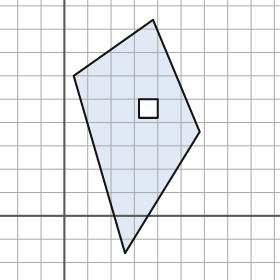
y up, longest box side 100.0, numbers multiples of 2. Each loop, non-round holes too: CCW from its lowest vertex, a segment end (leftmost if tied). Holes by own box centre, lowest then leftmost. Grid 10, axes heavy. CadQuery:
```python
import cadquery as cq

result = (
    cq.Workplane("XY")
    .moveTo(26.0, -16.0)
    .lineTo(58.0, 36.0)
    .lineTo(38.0, 84.0)
    .lineTo(4.0, 60.0)
    .close()
    .moveTo(32.0, 42.0)
    .lineTo(40.0, 42.0)
    .lineTo(40.0, 50.0)
    .lineTo(32.0, 50.0)
    .close()
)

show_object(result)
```